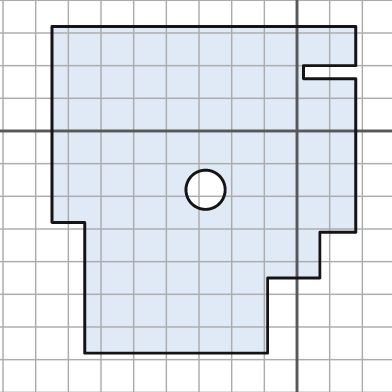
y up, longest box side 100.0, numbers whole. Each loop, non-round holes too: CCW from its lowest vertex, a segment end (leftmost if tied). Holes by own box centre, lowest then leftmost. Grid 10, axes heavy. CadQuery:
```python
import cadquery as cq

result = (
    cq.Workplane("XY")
    .moveTo(-65.0, -68.0)
    .lineTo(-9.0, -68.0)
    .lineTo(-9.0, -45.0)
    .lineTo(7.0, -45.0)
    .lineTo(7.0, -31.0)
    .lineTo(18.0, -31.0)
    .lineTo(18.0, 16.0)
    .lineTo(2.0, 16.0)
    .lineTo(2.0, 20.0)
    .lineTo(18.0, 20.0)
    .lineTo(18.0, 32.0)
    .lineTo(-75.0, 32.0)
    .lineTo(-75.0, -28.0)
    .lineTo(-65.0, -28.0)
    .close()
    .moveTo(-28.0, -18.0)
    .circle(6.0)
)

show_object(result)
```